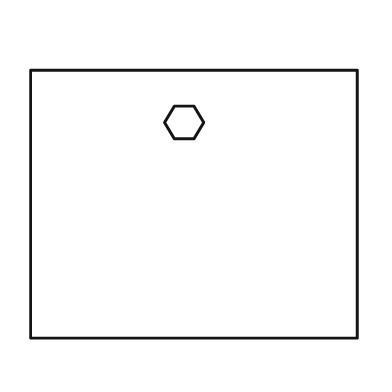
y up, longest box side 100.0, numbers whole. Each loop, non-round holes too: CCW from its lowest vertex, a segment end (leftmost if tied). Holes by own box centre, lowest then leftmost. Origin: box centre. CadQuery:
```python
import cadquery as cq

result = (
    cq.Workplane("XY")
    .moveTo(-50.0, -41.0)
    .lineTo(50.0, -41.0)
    .lineTo(50.0, 41.0)
    .lineTo(-50.0, 41.0)
    .close()
    .moveTo(-6.0, 20.0)
    .lineTo(0.0, 20.0)
    .lineTo(3.0, 25.0)
    .lineTo(0.0, 30.0)
    .lineTo(-6.0, 30.0)
    .lineTo(-9.0, 25.0)
    .close()
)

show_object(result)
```